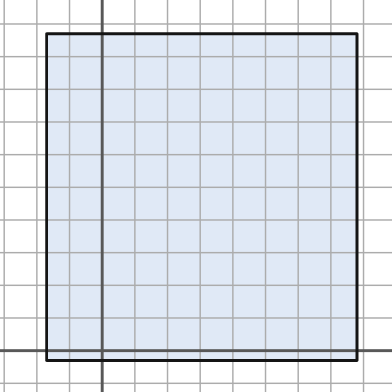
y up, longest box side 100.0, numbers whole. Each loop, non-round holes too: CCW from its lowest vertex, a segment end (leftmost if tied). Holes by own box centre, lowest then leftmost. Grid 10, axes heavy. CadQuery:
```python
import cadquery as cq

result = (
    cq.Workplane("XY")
    .moveTo(-17.0, -3.0)
    .lineTo(78.0, -3.0)
    .lineTo(78.0, 97.0)
    .lineTo(-17.0, 97.0)
    .close()
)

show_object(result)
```